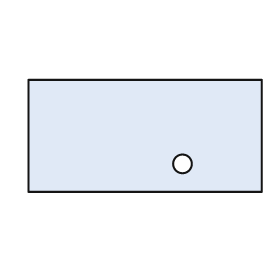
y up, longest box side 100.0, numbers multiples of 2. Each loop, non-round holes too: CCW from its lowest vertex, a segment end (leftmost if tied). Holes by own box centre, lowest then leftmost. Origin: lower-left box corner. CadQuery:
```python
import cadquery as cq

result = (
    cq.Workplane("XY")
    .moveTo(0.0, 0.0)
    .lineTo(100.0, 0.0)
    .lineTo(100.0, 48.0)
    .lineTo(0.0, 48.0)
    .close()
    .moveTo(66.0, 12.0)
    .circle(4.0)
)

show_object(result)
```